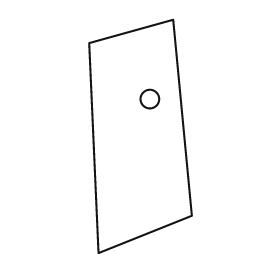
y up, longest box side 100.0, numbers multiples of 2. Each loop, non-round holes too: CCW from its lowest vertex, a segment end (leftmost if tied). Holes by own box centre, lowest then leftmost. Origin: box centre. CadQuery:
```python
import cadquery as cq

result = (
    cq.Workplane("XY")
    .moveTo(-18.0, -50.0)
    .lineTo(22.0, -34.0)
    .lineTo(14.0, 50.0)
    .lineTo(-22.0, 40.0)
    .close()
    .moveTo(4.0, 16.0)
    .circle(4.0)
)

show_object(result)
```